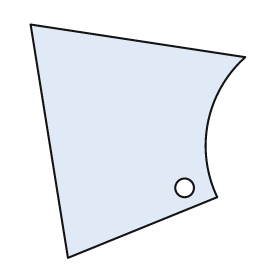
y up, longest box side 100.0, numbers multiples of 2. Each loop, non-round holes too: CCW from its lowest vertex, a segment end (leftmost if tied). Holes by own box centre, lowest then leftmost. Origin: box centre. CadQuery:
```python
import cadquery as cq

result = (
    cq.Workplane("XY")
    .moveTo(-30.0, -50.0)
    .lineTo(34.0, -24.0)
    .threePointArc((30.0, 8.0), (46.0, 36.0))
    .lineTo(-46.0, 50.0)
    .close()
    .moveTo(20.0, -20.0)
    .circle(4.0)
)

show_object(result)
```